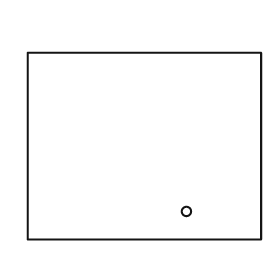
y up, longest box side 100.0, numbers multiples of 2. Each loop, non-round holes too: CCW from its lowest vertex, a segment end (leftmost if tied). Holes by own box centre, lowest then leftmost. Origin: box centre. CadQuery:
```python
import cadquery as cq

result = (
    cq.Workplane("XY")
    .moveTo(-50.0, -40.0)
    .lineTo(50.0, -40.0)
    .lineTo(50.0, 40.0)
    .lineTo(-50.0, 40.0)
    .close()
    .moveTo(18.0, -28.0)
    .circle(2.0)
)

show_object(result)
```